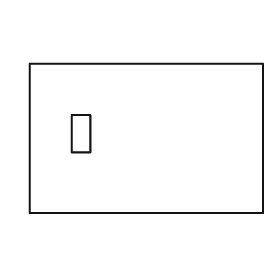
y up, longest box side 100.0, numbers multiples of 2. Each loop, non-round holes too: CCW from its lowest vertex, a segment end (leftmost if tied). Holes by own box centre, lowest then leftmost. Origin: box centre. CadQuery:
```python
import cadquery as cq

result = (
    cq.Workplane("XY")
    .moveTo(-50.0, -32.0)
    .lineTo(50.0, -32.0)
    .lineTo(50.0, 32.0)
    .lineTo(-50.0, 32.0)
    .close()
    .moveTo(-32.0, -6.0)
    .lineTo(-24.0, -6.0)
    .lineTo(-24.0, 10.0)
    .lineTo(-32.0, 10.0)
    .close()
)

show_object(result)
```